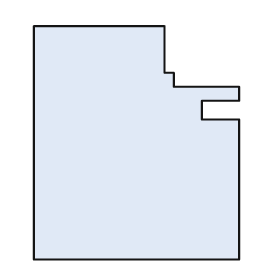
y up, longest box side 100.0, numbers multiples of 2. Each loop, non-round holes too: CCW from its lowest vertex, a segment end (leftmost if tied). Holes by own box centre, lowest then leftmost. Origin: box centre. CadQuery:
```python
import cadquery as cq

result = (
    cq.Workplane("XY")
    .moveTo(-44.0, -50.0)
    .lineTo(44.0, -50.0)
    .lineTo(44.0, 10.0)
    .lineTo(28.0, 10.0)
    .lineTo(28.0, 18.0)
    .lineTo(44.0, 18.0)
    .lineTo(44.0, 24.0)
    .lineTo(16.0, 24.0)
    .lineTo(16.0, 30.0)
    .lineTo(12.0, 30.0)
    .lineTo(12.0, 50.0)
    .lineTo(-44.0, 50.0)
    .close()
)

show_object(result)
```